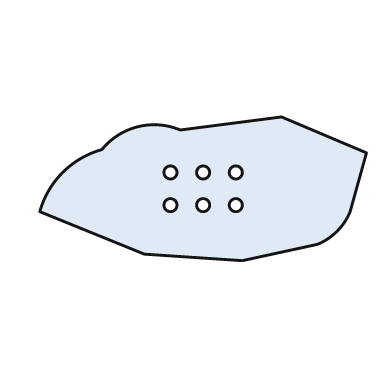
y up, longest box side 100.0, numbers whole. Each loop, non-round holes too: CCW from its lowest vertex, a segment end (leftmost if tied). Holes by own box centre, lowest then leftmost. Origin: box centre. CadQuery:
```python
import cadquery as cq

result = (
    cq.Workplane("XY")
    .moveTo(12.0, -22.0)
    .lineTo(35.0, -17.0)
    .threePointArc((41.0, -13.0), (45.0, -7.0))
    .lineTo(50.0, 11.0)
    .lineTo(24.0, 22.0)
    .lineTo(-7.0, 18.0)
    .threePointArc((-20.0, 19.0), (-31.0, 12.0))
    .threePointArc((-43.0, 5.0), (-50.0, -7.0))
    .lineTo(-18.0, -20.0)
    .close()
    .moveTo(-10.0, -5.0)
    .circle(2.0)
    .moveTo(0.0, -5.0)
    .circle(2.0)
    .moveTo(10.0, -5.0)
    .circle(2.0)
    .moveTo(-10.0, 5.0)
    .circle(2.0)
    .moveTo(0.0, 5.0)
    .circle(2.0)
    .moveTo(10.0, 5.0)
    .circle(2.0)
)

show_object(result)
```